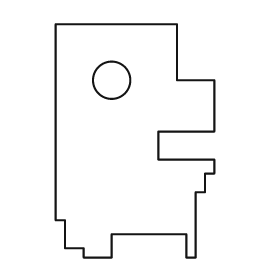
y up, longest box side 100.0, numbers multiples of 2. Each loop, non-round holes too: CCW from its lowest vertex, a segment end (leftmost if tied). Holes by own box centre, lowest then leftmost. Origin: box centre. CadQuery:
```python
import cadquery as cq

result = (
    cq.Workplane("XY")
    .moveTo(-22.0, -50.0)
    .lineTo(-10.0, -50.0)
    .lineTo(-10.0, -40.0)
    .lineTo(22.0, -40.0)
    .lineTo(22.0, -50.0)
    .lineTo(26.0, -50.0)
    .lineTo(26.0, -22.0)
    .lineTo(30.0, -22.0)
    .lineTo(30.0, -14.0)
    .lineTo(34.0, -14.0)
    .lineTo(34.0, -8.0)
    .lineTo(10.0, -8.0)
    .lineTo(10.0, 4.0)
    .lineTo(34.0, 4.0)
    .lineTo(34.0, 26.0)
    .lineTo(18.0, 26.0)
    .lineTo(18.0, 50.0)
    .lineTo(-34.0, 50.0)
    .lineTo(-34.0, -34.0)
    .lineTo(-30.0, -34.0)
    .lineTo(-30.0, -46.0)
    .lineTo(-22.0, -46.0)
    .close()
    .moveTo(-10.0, 26.0)
    .circle(8.0)
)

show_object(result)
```